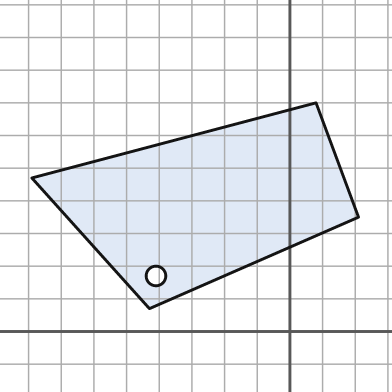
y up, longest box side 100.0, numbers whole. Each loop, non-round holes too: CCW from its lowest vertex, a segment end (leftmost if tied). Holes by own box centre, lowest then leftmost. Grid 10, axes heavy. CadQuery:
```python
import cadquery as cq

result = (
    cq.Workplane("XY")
    .moveTo(-43.0, 7.0)
    .lineTo(21.0, 35.0)
    .lineTo(8.0, 70.0)
    .lineTo(-79.0, 47.0)
    .close()
    .moveTo(-41.0, 17.0)
    .circle(3.0)
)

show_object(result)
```